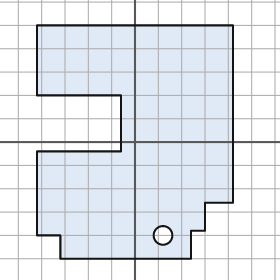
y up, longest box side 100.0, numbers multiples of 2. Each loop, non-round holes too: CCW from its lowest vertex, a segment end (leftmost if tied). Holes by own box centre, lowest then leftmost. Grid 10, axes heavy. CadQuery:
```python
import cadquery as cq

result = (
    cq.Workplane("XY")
    .moveTo(-32.0, -50.0)
    .lineTo(24.0, -50.0)
    .lineTo(24.0, -38.0)
    .lineTo(30.0, -38.0)
    .lineTo(30.0, -26.0)
    .lineTo(42.0, -26.0)
    .lineTo(42.0, 50.0)
    .lineTo(-42.0, 50.0)
    .lineTo(-42.0, 20.0)
    .lineTo(-6.0, 20.0)
    .lineTo(-6.0, -4.0)
    .lineTo(-42.0, -4.0)
    .lineTo(-42.0, -40.0)
    .lineTo(-32.0, -40.0)
    .close()
    .moveTo(12.0, -40.0)
    .circle(4.0)
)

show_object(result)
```